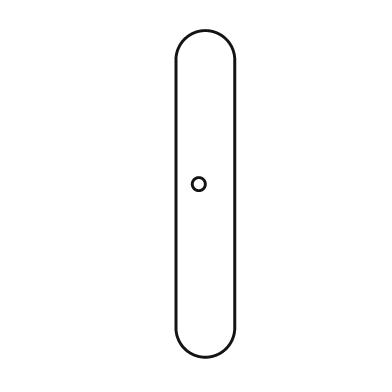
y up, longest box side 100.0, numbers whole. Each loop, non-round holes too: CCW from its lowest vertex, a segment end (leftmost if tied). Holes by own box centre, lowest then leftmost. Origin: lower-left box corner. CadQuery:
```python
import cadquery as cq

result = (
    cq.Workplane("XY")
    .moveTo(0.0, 9.0)
    .threePointArc((9.0, 0.0), (18.0, 9.0))
    .lineTo(18.0, 91.0)
    .threePointArc((9.0, 100.0), (0.0, 91.0))
    .close()
    .moveTo(7.0, 53.0)
    .circle(2.0)
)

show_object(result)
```